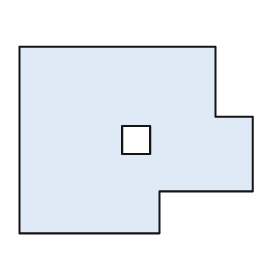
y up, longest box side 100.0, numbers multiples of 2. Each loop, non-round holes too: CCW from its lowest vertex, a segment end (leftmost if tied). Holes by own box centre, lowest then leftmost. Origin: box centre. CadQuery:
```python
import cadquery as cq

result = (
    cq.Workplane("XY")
    .moveTo(-50.0, -40.0)
    .lineTo(10.0, -40.0)
    .lineTo(10.0, -22.0)
    .lineTo(50.0, -22.0)
    .lineTo(50.0, 10.0)
    .lineTo(34.0, 10.0)
    .lineTo(34.0, 40.0)
    .lineTo(-50.0, 40.0)
    .close()
    .moveTo(-6.0, -6.0)
    .lineTo(6.0, -6.0)
    .lineTo(6.0, 6.0)
    .lineTo(-6.0, 6.0)
    .close()
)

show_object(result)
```